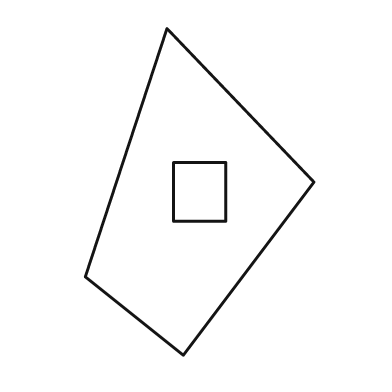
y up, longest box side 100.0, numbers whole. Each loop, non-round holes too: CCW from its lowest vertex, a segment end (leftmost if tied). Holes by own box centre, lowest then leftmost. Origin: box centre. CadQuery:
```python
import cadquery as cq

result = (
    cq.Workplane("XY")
    .moveTo(-5.0, -50.0)
    .lineTo(35.0, 3.0)
    .lineTo(-10.0, 50.0)
    .lineTo(-35.0, -26.0)
    .close()
    .moveTo(-8.0, -9.0)
    .lineTo(8.0, -9.0)
    .lineTo(8.0, 9.0)
    .lineTo(-8.0, 9.0)
    .close()
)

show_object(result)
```